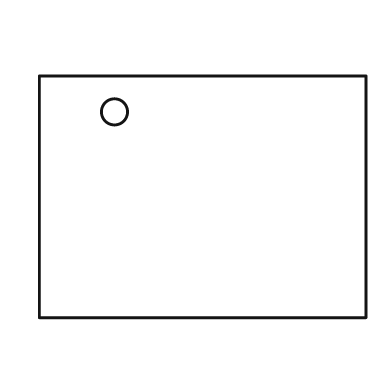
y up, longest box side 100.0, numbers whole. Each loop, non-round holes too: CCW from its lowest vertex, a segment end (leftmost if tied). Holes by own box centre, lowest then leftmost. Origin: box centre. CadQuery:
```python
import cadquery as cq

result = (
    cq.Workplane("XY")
    .moveTo(-50.0, -37.0)
    .lineTo(50.0, -37.0)
    .lineTo(50.0, 37.0)
    .lineTo(-50.0, 37.0)
    .close()
    .moveTo(-27.0, 26.0)
    .circle(4.0)
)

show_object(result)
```